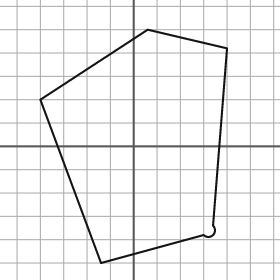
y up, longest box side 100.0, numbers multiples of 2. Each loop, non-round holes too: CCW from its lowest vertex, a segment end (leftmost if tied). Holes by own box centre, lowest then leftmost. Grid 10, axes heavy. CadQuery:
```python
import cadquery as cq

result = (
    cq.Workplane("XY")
    .moveTo(-14.0, -50.0)
    .lineTo(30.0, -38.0)
    .threePointArc((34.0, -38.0), (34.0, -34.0))
    .lineTo(40.0, 42.0)
    .lineTo(6.0, 50.0)
    .lineTo(-40.0, 20.0)
    .close()
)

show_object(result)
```